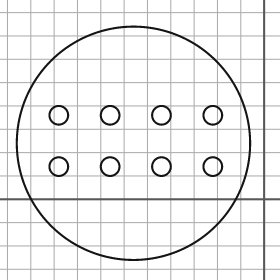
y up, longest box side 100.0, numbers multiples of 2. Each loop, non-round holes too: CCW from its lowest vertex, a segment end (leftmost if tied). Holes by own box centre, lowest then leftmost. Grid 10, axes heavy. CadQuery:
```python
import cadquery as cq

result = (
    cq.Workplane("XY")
    .moveTo(-56.0, 24.0)
    .circle(50.0)
    .moveTo(-88.0, 14.0)
    .circle(4.0)
    .moveTo(-66.0, 14.0)
    .circle(4.0)
    .moveTo(-44.0, 14.0)
    .circle(4.0)
    .moveTo(-22.0, 14.0)
    .circle(4.0)
    .moveTo(-88.0, 36.0)
    .circle(4.0)
    .moveTo(-66.0, 36.0)
    .circle(4.0)
    .moveTo(-44.0, 36.0)
    .circle(4.0)
    .moveTo(-22.0, 36.0)
    .circle(4.0)
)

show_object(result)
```